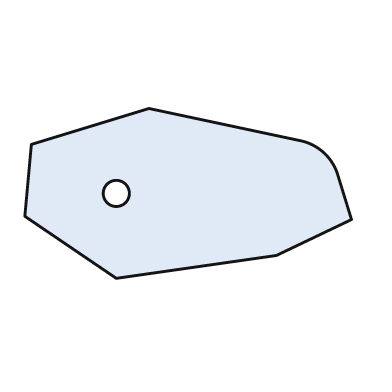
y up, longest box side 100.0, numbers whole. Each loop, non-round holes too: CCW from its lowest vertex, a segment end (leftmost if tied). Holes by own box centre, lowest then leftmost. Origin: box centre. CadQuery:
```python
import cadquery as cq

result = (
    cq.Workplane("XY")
    .moveTo(-22.0, -26.0)
    .lineTo(27.0, -19.0)
    .lineTo(50.0, -8.0)
    .lineTo(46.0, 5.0)
    .threePointArc((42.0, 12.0), (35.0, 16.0))
    .lineTo(-12.0, 26.0)
    .lineTo(-48.0, 15.0)
    .lineTo(-50.0, -7.0)
    .close()
    .moveTo(-22.0, 0.0)
    .circle(4.0)
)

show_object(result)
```